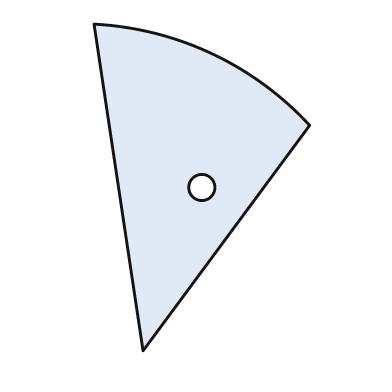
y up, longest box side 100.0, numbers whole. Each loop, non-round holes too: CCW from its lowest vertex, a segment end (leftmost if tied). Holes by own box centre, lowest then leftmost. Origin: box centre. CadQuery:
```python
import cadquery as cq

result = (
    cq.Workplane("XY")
    .moveTo(-18.0, -50.0)
    .lineTo(33.0, 19.0)
    .threePointArc((3.0, 41.0), (-33.0, 50.0))
    .close()
    .moveTo(0.0, 0.0)
    .circle(4.0)
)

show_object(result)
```